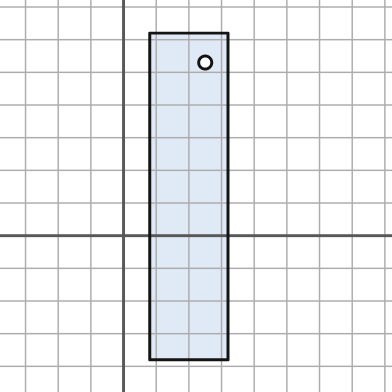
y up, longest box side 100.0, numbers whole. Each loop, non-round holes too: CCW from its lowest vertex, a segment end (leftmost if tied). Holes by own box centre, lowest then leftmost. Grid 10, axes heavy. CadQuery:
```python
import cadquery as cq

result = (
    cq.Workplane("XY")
    .moveTo(8.0, -38.0)
    .lineTo(32.0, -38.0)
    .lineTo(32.0, 62.0)
    .lineTo(8.0, 62.0)
    .close()
    .moveTo(25.0, 53.0)
    .circle(2.0)
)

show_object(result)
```